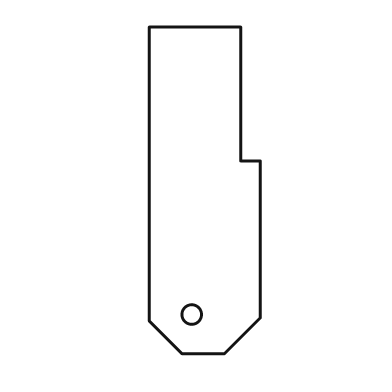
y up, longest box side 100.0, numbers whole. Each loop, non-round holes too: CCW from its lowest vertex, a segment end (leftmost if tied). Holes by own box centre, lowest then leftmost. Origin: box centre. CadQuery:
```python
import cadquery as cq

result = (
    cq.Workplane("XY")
    .moveTo(-7.0, -50.0)
    .lineTo(6.0, -50.0)
    .lineTo(17.0, -39.0)
    .lineTo(17.0, 9.0)
    .lineTo(11.0, 9.0)
    .lineTo(11.0, 50.0)
    .lineTo(-17.0, 50.0)
    .lineTo(-17.0, -40.0)
    .close()
    .moveTo(-4.0, -38.0)
    .circle(3.0)
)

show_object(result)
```